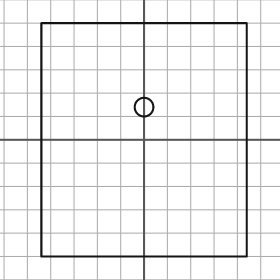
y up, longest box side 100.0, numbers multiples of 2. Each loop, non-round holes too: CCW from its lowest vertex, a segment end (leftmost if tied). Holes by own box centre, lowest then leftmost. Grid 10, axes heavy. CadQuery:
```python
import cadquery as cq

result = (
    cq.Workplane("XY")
    .moveTo(-44.0, -50.0)
    .lineTo(44.0, -50.0)
    .lineTo(44.0, 50.0)
    .lineTo(-44.0, 50.0)
    .close()
    .moveTo(0.0, 14.0)
    .circle(4.0)
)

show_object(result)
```